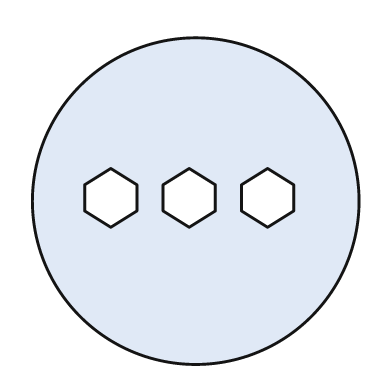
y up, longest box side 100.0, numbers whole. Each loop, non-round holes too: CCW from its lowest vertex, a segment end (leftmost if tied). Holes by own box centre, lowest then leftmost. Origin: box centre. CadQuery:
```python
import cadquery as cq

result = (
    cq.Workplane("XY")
    .moveTo(0.0, 0.0)
    .circle(50.0)
    .moveTo(-26.0, -8.0)
    .lineTo(-18.0, -3.0)
    .lineTo(-18.0, 5.0)
    .lineTo(-26.0, 10.0)
    .lineTo(-34.0, 5.0)
    .lineTo(-34.0, -3.0)
    .close()
    .moveTo(-2.0, -8.0)
    .lineTo(6.0, -3.0)
    .lineTo(6.0, 5.0)
    .lineTo(-2.0, 10.0)
    .lineTo(-10.0, 5.0)
    .lineTo(-10.0, -3.0)
    .close()
    .moveTo(22.0, -8.0)
    .lineTo(30.0, -3.0)
    .lineTo(30.0, 5.0)
    .lineTo(22.0, 10.0)
    .lineTo(14.0, 5.0)
    .lineTo(14.0, -3.0)
    .close()
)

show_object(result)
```